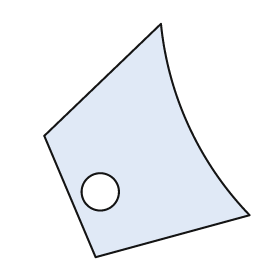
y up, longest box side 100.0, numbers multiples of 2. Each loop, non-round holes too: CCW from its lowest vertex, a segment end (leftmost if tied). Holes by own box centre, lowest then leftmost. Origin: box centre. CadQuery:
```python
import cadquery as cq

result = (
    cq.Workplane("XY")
    .moveTo(-22.0, -50.0)
    .lineTo(44.0, -32.0)
    .threePointArc((18.0, 6.0), (6.0, 50.0))
    .lineTo(-44.0, 2.0)
    .close()
    .moveTo(-20.0, -22.0)
    .circle(8.0)
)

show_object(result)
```